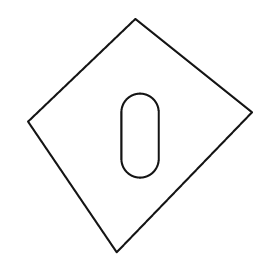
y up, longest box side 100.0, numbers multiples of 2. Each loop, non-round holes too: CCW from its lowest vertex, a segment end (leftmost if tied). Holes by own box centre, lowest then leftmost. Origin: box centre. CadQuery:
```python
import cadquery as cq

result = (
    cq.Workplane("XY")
    .moveTo(-10.0, -50.0)
    .lineTo(48.0, 10.0)
    .lineTo(-2.0, 50.0)
    .lineTo(-48.0, 6.0)
    .close()
    .moveTo(-8.0, -10.0)
    .threePointArc((0.0, -18.0), (8.0, -10.0))
    .lineTo(8.0, 10.0)
    .threePointArc((0.0, 18.0), (-8.0, 10.0))
    .close()
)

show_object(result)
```